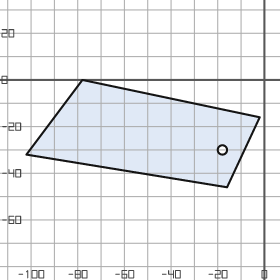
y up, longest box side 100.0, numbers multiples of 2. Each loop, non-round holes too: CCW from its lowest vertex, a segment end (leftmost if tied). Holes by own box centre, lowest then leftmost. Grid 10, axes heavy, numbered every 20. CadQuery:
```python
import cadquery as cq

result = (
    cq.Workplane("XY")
    .moveTo(-16.0, -46.0)
    .lineTo(-2.0, -16.0)
    .lineTo(-78.0, 0.0)
    .lineTo(-102.0, -32.0)
    .close()
    .moveTo(-18.0, -30.0)
    .circle(2.0)
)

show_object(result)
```